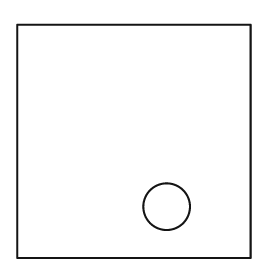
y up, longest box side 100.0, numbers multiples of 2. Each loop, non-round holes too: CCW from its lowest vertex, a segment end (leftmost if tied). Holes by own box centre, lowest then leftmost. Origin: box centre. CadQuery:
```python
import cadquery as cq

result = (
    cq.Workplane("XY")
    .moveTo(-50.0, -50.0)
    .lineTo(50.0, -50.0)
    .lineTo(50.0, 50.0)
    .lineTo(-50.0, 50.0)
    .close()
    .moveTo(14.0, -28.0)
    .circle(10.0)
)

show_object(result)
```